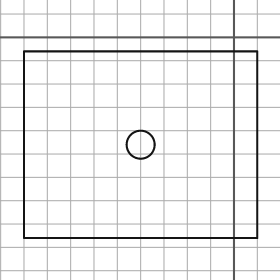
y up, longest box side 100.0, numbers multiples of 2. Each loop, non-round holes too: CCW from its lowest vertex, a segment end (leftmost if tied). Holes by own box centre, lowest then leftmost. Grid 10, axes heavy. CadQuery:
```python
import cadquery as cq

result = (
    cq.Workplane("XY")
    .moveTo(-90.0, -86.0)
    .lineTo(10.0, -86.0)
    .lineTo(10.0, -6.0)
    .lineTo(-90.0, -6.0)
    .close()
    .moveTo(-40.0, -46.0)
    .circle(6.0)
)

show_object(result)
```